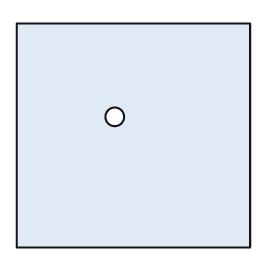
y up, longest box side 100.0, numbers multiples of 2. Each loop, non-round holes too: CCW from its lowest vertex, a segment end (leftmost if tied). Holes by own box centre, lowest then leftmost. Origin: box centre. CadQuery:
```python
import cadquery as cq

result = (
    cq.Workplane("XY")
    .moveTo(-50.0, -48.0)
    .lineTo(50.0, -48.0)
    .lineTo(50.0, 48.0)
    .lineTo(-50.0, 48.0)
    .close()
    .moveTo(-8.0, 8.0)
    .circle(4.0)
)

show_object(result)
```